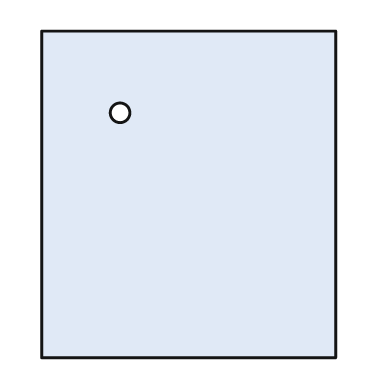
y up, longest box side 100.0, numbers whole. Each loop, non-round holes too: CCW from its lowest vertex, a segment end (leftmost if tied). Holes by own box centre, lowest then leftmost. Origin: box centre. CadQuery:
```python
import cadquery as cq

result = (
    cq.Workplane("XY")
    .moveTo(-45.0, -50.0)
    .lineTo(45.0, -50.0)
    .lineTo(45.0, 50.0)
    .lineTo(-45.0, 50.0)
    .close()
    .moveTo(-21.0, 25.0)
    .circle(3.0)
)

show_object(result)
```